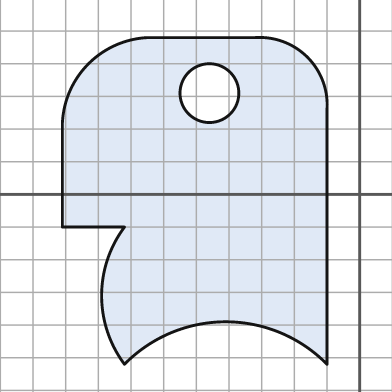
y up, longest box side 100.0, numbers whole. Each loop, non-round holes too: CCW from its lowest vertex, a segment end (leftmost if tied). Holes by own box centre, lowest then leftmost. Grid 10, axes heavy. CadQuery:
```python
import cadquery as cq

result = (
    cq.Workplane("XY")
    .moveTo(-72.0, -52.0)
    .threePointArc((-41.0, -39.0), (-10.0, -52.0))
    .lineTo(-10.0, 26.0)
    .threePointArc((-16.0, 42.0), (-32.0, 48.0))
    .lineTo(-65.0, 48.0)
    .threePointArc((-83.0, 40.0), (-91.0, 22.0))
    .lineTo(-91.0, -10.0)
    .lineTo(-72.0, -10.0)
    .threePointArc((-79.0, -31.0), (-72.0, -52.0))
    .close()
    .moveTo(-46.0, 31.0)
    .circle(9.0)
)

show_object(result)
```